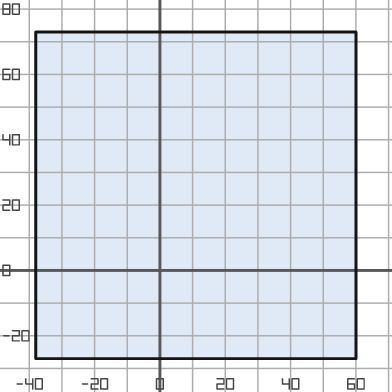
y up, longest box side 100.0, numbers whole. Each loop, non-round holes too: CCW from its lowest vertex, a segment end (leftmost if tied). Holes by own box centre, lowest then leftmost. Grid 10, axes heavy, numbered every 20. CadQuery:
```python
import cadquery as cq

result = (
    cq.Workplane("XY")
    .moveTo(-38.0, -27.0)
    .lineTo(60.0, -27.0)
    .lineTo(60.0, 73.0)
    .lineTo(-38.0, 73.0)
    .close()
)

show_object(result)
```